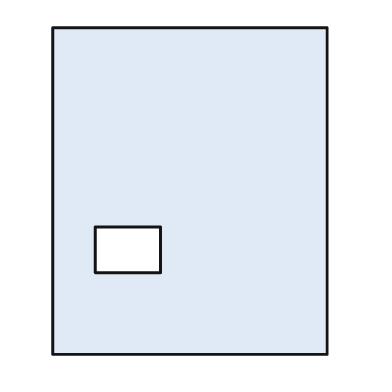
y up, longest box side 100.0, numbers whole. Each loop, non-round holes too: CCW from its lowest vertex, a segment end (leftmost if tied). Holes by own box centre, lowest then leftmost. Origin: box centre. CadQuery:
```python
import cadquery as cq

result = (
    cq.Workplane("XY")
    .moveTo(-42.0, -50.0)
    .lineTo(42.0, -50.0)
    .lineTo(42.0, 50.0)
    .lineTo(-42.0, 50.0)
    .close()
    .moveTo(-29.0, -25.0)
    .lineTo(-9.0, -25.0)
    .lineTo(-9.0, -11.0)
    .lineTo(-29.0, -11.0)
    .close()
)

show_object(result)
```